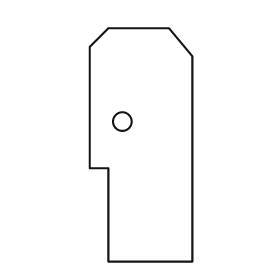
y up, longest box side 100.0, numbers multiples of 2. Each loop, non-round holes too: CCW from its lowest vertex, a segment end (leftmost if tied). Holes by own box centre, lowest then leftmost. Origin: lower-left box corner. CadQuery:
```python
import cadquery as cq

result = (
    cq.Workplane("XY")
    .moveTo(8.0, 0.0)
    .lineTo(44.0, 0.0)
    .lineTo(44.0, 88.0)
    .lineTo(34.0, 100.0)
    .lineTo(8.0, 100.0)
    .lineTo(0.0, 92.0)
    .lineTo(0.0, 40.0)
    .lineTo(8.0, 40.0)
    .close()
    .moveTo(14.0, 60.0)
    .circle(4.0)
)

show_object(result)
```